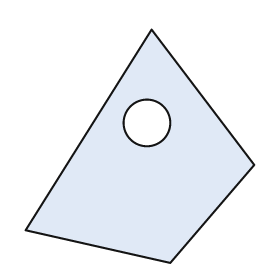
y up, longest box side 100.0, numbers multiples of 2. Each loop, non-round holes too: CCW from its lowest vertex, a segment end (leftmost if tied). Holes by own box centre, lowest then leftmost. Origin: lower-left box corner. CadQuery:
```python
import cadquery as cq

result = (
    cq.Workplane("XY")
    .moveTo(62.0, 0.0)
    .lineTo(98.0, 42.0)
    .lineTo(54.0, 100.0)
    .lineTo(0.0, 14.0)
    .close()
    .moveTo(52.0, 60.0)
    .circle(10.0)
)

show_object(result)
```